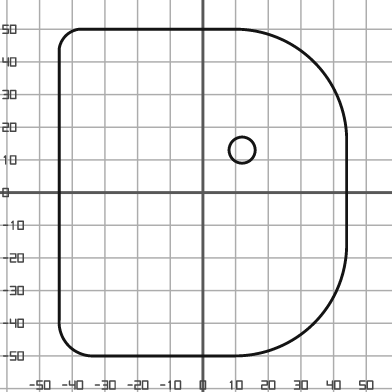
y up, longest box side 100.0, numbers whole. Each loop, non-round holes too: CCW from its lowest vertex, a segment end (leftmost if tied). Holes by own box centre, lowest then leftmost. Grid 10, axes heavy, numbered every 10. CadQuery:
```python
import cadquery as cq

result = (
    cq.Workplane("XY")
    .moveTo(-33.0, -50.0)
    .lineTo(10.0, -50.0)
    .threePointArc((34.0, -40.0), (44.0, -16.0))
    .lineTo(44.0, 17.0)
    .threePointArc((34.0, 40.0), (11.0, 50.0))
    .lineTo(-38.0, 50.0)
    .threePointArc((-42.0, 48.0), (-44.0, 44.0))
    .lineTo(-44.0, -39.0)
    .threePointArc((-41.0, -47.0), (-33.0, -50.0))
    .close()
    .moveTo(12.0, 13.0)
    .circle(4.0)
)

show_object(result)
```